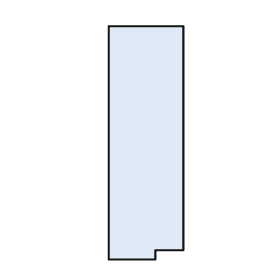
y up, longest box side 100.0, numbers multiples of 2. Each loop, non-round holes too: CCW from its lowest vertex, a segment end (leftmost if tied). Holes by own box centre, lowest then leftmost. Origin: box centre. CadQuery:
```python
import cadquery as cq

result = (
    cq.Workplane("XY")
    .moveTo(-16.0, -50.0)
    .lineTo(4.0, -50.0)
    .lineTo(4.0, -46.0)
    .lineTo(16.0, -46.0)
    .lineTo(16.0, 50.0)
    .lineTo(-16.0, 50.0)
    .close()
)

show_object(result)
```